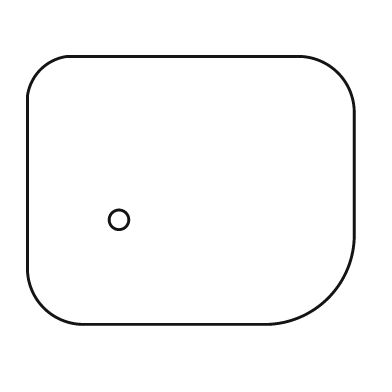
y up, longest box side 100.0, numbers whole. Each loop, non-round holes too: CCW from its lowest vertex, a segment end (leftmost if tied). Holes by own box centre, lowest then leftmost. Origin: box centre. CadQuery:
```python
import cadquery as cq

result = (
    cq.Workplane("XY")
    .moveTo(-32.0, -41.0)
    .lineTo(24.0, -41.0)
    .threePointArc((42.0, -33.0), (50.0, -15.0))
    .lineTo(50.0, 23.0)
    .threePointArc((45.0, 36.0), (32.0, 41.0))
    .lineTo(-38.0, 41.0)
    .threePointArc((-46.0, 37.0), (-50.0, 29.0))
    .lineTo(-50.0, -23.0)
    .threePointArc((-45.0, -36.0), (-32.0, -41.0))
    .close()
    .moveTo(-22.0, -9.0)
    .circle(3.0)
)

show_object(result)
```